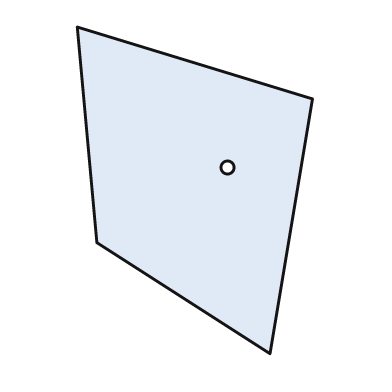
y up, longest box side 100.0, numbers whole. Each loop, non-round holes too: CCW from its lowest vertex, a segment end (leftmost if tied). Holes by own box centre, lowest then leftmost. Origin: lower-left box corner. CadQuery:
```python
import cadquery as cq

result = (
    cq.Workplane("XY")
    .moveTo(59.0, 0.0)
    .lineTo(72.0, 78.0)
    .lineTo(0.0, 100.0)
    .lineTo(6.0, 34.0)
    .close()
    .moveTo(46.0, 57.0)
    .circle(2.0)
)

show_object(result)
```